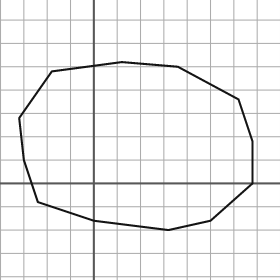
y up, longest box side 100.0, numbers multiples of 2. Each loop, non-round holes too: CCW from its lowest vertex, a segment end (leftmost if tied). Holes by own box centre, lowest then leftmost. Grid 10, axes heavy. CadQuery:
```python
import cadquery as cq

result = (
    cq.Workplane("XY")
    .moveTo(32.0, -20.0)
    .lineTo(50.0, -16.0)
    .lineTo(68.0, 0.0)
    .lineTo(68.0, 18.0)
    .lineTo(62.0, 36.0)
    .lineTo(36.0, 50.0)
    .lineTo(12.0, 52.0)
    .lineTo(-18.0, 48.0)
    .lineTo(-32.0, 28.0)
    .lineTo(-30.0, 10.0)
    .lineTo(-24.0, -8.0)
    .lineTo(0.0, -16.0)
    .close()
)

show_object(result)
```